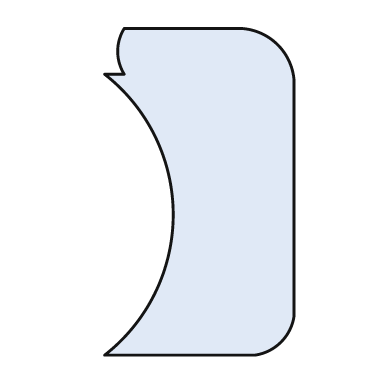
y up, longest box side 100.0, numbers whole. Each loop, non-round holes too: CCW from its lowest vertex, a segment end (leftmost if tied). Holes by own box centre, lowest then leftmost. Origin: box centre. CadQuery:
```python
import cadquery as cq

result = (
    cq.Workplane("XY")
    .moveTo(-29.0, -50.0)
    .lineTo(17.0, -50.0)
    .threePointArc((25.0, -46.0), (29.0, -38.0))
    .lineTo(29.0, 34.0)
    .threePointArc((24.0, 45.0), (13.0, 50.0))
    .lineTo(-23.0, 50.0)
    .threePointArc((-25.0, 43.0), (-23.0, 36.0))
    .lineTo(-29.0, 36.0)
    .threePointArc((-8.0, -7.0), (-29.0, -50.0))
    .close()
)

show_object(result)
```